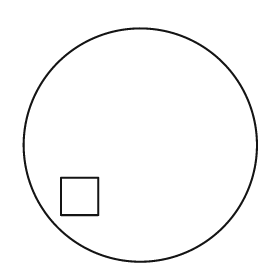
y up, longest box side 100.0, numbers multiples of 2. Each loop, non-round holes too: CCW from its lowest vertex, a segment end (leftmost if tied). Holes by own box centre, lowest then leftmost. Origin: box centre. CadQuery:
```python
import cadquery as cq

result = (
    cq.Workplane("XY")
    .moveTo(0.0, 0.0)
    .circle(50.0)
    .moveTo(-34.0, -30.0)
    .lineTo(-18.0, -30.0)
    .lineTo(-18.0, -14.0)
    .lineTo(-34.0, -14.0)
    .close()
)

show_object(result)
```